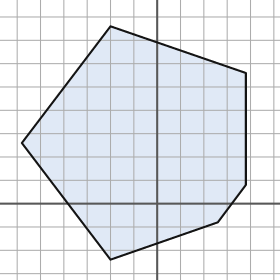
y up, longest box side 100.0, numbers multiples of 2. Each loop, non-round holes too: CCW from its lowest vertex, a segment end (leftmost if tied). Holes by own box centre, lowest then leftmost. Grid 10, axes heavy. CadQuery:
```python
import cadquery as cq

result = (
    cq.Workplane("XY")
    .moveTo(-20.0, -24.0)
    .lineTo(26.0, -8.0)
    .lineTo(38.0, 8.0)
    .lineTo(38.0, 56.0)
    .lineTo(-20.0, 76.0)
    .lineTo(-58.0, 26.0)
    .close()
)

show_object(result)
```